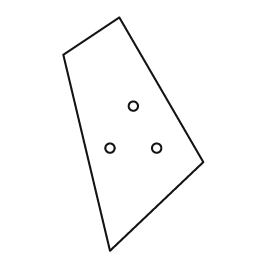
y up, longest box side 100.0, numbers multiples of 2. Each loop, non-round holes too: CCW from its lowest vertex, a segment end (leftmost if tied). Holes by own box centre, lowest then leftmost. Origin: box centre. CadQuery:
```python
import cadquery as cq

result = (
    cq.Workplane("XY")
    .moveTo(-10.0, -50.0)
    .lineTo(30.0, -12.0)
    .lineTo(-6.0, 50.0)
    .lineTo(-30.0, 34.0)
    .close()
    .moveTo(-10.0, -6.0)
    .circle(2.0)
    .moveTo(10.0, -6.0)
    .circle(2.0)
    .moveTo(0.0, 12.0)
    .circle(2.0)
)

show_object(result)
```